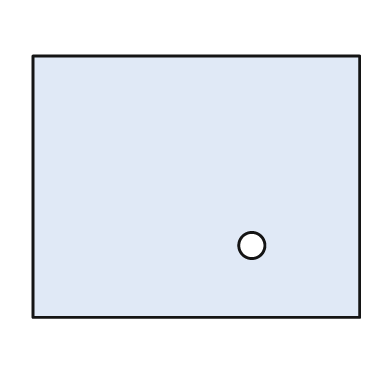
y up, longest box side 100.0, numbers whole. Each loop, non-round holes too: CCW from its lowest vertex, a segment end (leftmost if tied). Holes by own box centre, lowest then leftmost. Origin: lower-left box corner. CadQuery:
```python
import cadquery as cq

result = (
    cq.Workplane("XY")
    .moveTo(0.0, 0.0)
    .lineTo(100.0, 0.0)
    .lineTo(100.0, 80.0)
    .lineTo(0.0, 80.0)
    .close()
    .moveTo(67.0, 22.0)
    .circle(4.0)
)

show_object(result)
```